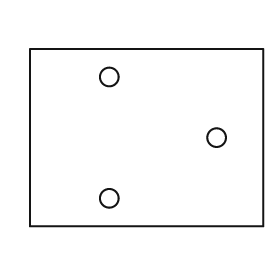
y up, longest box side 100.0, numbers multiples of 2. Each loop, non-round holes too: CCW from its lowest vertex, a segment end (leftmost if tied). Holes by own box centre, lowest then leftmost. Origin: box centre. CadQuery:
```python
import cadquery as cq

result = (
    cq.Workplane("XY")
    .moveTo(-50.0, -38.0)
    .lineTo(50.0, -38.0)
    .lineTo(50.0, 38.0)
    .lineTo(-50.0, 38.0)
    .close()
    .moveTo(-16.0, -26.0)
    .circle(4.0)
    .moveTo(30.0, 0.0)
    .circle(4.0)
    .moveTo(-16.0, 26.0)
    .circle(4.0)
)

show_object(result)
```